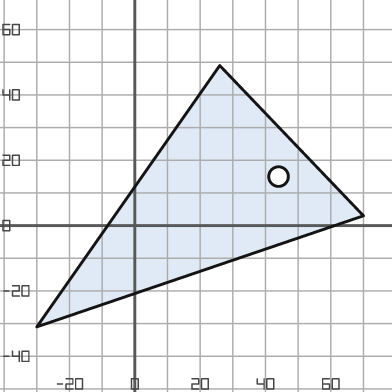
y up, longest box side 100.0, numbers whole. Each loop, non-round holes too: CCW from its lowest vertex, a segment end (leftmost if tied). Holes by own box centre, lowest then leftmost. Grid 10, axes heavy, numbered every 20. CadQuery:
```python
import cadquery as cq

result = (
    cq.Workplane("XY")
    .moveTo(-30.0, -31.0)
    .lineTo(70.0, 3.0)
    .lineTo(26.0, 49.0)
    .close()
    .moveTo(44.0, 15.0)
    .circle(3.0)
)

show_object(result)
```